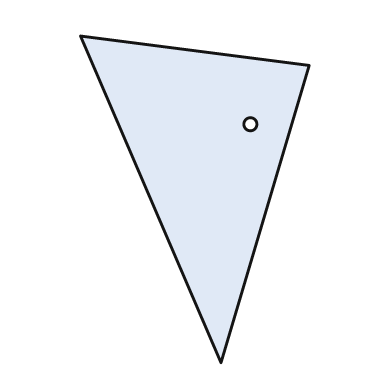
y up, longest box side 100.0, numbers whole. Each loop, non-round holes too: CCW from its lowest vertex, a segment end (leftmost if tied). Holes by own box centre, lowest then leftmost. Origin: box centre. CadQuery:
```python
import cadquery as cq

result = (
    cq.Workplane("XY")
    .moveTo(8.0, -50.0)
    .lineTo(35.0, 41.0)
    .lineTo(-35.0, 50.0)
    .close()
    .moveTo(17.0, 23.0)
    .circle(2.0)
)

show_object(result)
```